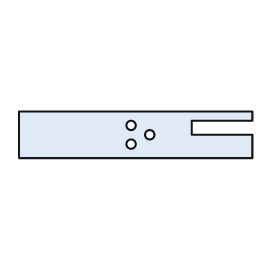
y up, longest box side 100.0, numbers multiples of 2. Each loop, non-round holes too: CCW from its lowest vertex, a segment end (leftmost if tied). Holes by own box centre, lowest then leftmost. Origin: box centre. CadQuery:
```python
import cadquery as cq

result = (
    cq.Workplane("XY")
    .moveTo(-50.0, -10.0)
    .lineTo(50.0, -10.0)
    .lineTo(50.0, 0.0)
    .lineTo(24.0, 0.0)
    .lineTo(24.0, 6.0)
    .lineTo(50.0, 6.0)
    .lineTo(50.0, 10.0)
    .lineTo(-50.0, 10.0)
    .close()
    .moveTo(-2.0, -4.0)
    .circle(2.0)
    .moveTo(6.0, 0.0)
    .circle(2.0)
    .moveTo(-2.0, 4.0)
    .circle(2.0)
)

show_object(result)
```